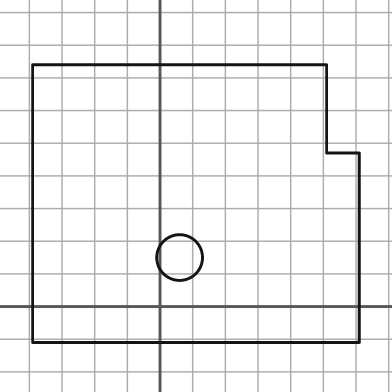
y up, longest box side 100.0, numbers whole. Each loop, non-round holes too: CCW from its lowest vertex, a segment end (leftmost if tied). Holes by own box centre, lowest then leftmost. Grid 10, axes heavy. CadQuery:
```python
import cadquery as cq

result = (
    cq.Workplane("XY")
    .moveTo(-39.0, -11.0)
    .lineTo(61.0, -11.0)
    .lineTo(61.0, 47.0)
    .lineTo(51.0, 47.0)
    .lineTo(51.0, 74.0)
    .lineTo(-39.0, 74.0)
    .close()
    .moveTo(6.0, 15.0)
    .circle(7.0)
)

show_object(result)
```